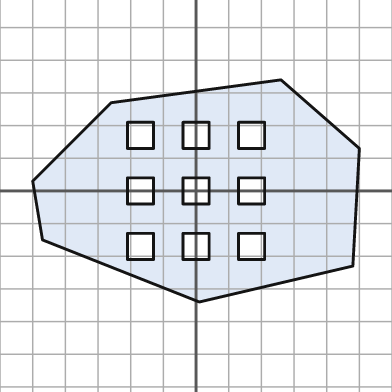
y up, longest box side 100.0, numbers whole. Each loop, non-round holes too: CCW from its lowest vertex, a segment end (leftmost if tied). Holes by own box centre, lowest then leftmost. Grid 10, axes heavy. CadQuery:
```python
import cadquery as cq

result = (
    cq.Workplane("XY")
    .moveTo(1.0, -34.0)
    .lineTo(48.0, -23.0)
    .lineTo(50.0, 13.0)
    .lineTo(26.0, 34.0)
    .lineTo(-26.0, 27.0)
    .lineTo(-50.0, 3.0)
    .lineTo(-47.0, -15.0)
    .close()
    .moveTo(-21.0, -21.0)
    .lineTo(-13.0, -21.0)
    .lineTo(-13.0, -13.0)
    .lineTo(-21.0, -13.0)
    .close()
    .moveTo(-4.0, -21.0)
    .lineTo(4.0, -21.0)
    .lineTo(4.0, -13.0)
    .lineTo(-4.0, -13.0)
    .close()
    .moveTo(13.0, -21.0)
    .lineTo(21.0, -21.0)
    .lineTo(21.0, -13.0)
    .lineTo(13.0, -13.0)
    .close()
    .moveTo(-21.0, -4.0)
    .lineTo(-13.0, -4.0)
    .lineTo(-13.0, 4.0)
    .lineTo(-21.0, 4.0)
    .close()
    .moveTo(-4.0, -4.0)
    .lineTo(4.0, -4.0)
    .lineTo(4.0, 4.0)
    .lineTo(-4.0, 4.0)
    .close()
    .moveTo(13.0, -4.0)
    .lineTo(21.0, -4.0)
    .lineTo(21.0, 4.0)
    .lineTo(13.0, 4.0)
    .close()
    .moveTo(-21.0, 13.0)
    .lineTo(-13.0, 13.0)
    .lineTo(-13.0, 21.0)
    .lineTo(-21.0, 21.0)
    .close()
    .moveTo(-4.0, 13.0)
    .lineTo(4.0, 13.0)
    .lineTo(4.0, 21.0)
    .lineTo(-4.0, 21.0)
    .close()
    .moveTo(13.0, 13.0)
    .lineTo(21.0, 13.0)
    .lineTo(21.0, 21.0)
    .lineTo(13.0, 21.0)
    .close()
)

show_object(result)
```